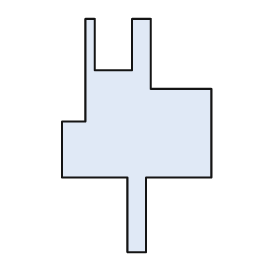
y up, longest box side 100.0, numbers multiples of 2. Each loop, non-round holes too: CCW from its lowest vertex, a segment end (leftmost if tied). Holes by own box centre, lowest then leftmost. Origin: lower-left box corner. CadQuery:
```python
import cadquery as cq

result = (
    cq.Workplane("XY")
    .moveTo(28.0, 0.0)
    .lineTo(36.0, 0.0)
    .lineTo(36.0, 32.0)
    .lineTo(64.0, 32.0)
    .lineTo(64.0, 70.0)
    .lineTo(38.0, 70.0)
    .lineTo(38.0, 100.0)
    .lineTo(30.0, 100.0)
    .lineTo(30.0, 78.0)
    .lineTo(14.0, 78.0)
    .lineTo(14.0, 100.0)
    .lineTo(10.0, 100.0)
    .lineTo(10.0, 56.0)
    .lineTo(0.0, 56.0)
    .lineTo(0.0, 32.0)
    .lineTo(28.0, 32.0)
    .close()
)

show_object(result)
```